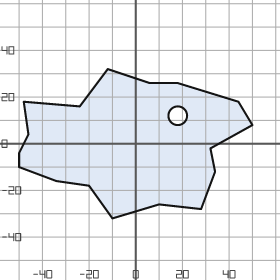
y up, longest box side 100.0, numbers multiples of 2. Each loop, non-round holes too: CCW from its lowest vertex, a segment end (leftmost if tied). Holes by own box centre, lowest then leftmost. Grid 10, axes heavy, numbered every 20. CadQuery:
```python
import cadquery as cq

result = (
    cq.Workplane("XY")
    .moveTo(-10.0, -32.0)
    .lineTo(10.0, -26.0)
    .lineTo(28.0, -28.0)
    .lineTo(34.0, -12.0)
    .lineTo(32.0, -2.0)
    .lineTo(50.0, 8.0)
    .lineTo(44.0, 18.0)
    .lineTo(18.0, 26.0)
    .lineTo(6.0, 26.0)
    .lineTo(-12.0, 32.0)
    .lineTo(-24.0, 16.0)
    .lineTo(-48.0, 18.0)
    .lineTo(-46.0, 4.0)
    .lineTo(-50.0, -4.0)
    .lineTo(-50.0, -10.0)
    .lineTo(-34.0, -16.0)
    .lineTo(-20.0, -18.0)
    .close()
    .moveTo(18.0, 12.0)
    .circle(4.0)
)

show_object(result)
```